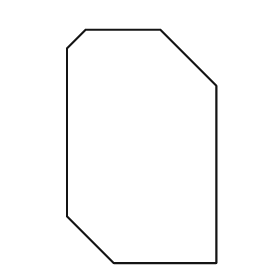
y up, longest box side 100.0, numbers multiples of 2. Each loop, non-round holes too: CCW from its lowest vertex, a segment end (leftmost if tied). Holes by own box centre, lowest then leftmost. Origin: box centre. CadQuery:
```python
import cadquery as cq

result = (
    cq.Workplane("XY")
    .moveTo(-12.0, -50.0)
    .lineTo(32.0, -50.0)
    .lineTo(32.0, 26.0)
    .lineTo(8.0, 50.0)
    .lineTo(-24.0, 50.0)
    .lineTo(-32.0, 42.0)
    .lineTo(-32.0, -30.0)
    .close()
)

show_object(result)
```